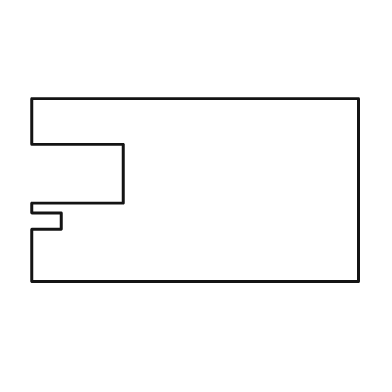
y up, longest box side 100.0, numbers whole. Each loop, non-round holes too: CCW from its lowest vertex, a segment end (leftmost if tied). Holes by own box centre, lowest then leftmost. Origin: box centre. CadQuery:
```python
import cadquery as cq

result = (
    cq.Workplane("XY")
    .moveTo(-50.0, -28.0)
    .lineTo(50.0, -28.0)
    .lineTo(50.0, 28.0)
    .lineTo(-50.0, 28.0)
    .lineTo(-50.0, 14.0)
    .lineTo(-22.0, 14.0)
    .lineTo(-22.0, -4.0)
    .lineTo(-50.0, -4.0)
    .lineTo(-50.0, -7.0)
    .lineTo(-41.0, -7.0)
    .lineTo(-41.0, -12.0)
    .lineTo(-50.0, -12.0)
    .close()
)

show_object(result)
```